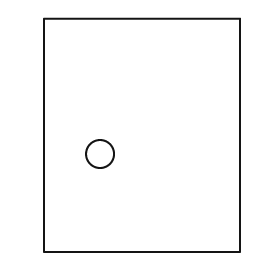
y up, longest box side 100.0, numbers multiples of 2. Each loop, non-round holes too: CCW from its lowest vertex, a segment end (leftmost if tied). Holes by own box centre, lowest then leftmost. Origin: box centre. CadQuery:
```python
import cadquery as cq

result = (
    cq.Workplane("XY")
    .moveTo(-42.0, -50.0)
    .lineTo(42.0, -50.0)
    .lineTo(42.0, 50.0)
    .lineTo(-42.0, 50.0)
    .close()
    .moveTo(-18.0, -8.0)
    .circle(6.0)
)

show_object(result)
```